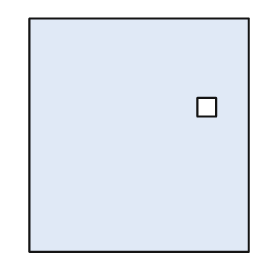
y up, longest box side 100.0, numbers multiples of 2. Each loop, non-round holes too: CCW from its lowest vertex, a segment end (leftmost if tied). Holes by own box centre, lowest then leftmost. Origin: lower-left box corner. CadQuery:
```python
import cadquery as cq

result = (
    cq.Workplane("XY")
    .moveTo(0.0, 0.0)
    .lineTo(94.0, 0.0)
    .lineTo(94.0, 100.0)
    .lineTo(0.0, 100.0)
    .close()
    .moveTo(72.0, 58.0)
    .lineTo(80.0, 58.0)
    .lineTo(80.0, 66.0)
    .lineTo(72.0, 66.0)
    .close()
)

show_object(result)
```